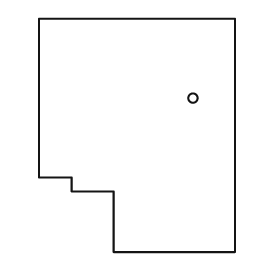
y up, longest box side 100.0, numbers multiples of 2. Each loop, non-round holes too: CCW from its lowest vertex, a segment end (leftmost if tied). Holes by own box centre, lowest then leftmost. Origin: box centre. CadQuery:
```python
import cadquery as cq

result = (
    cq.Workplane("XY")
    .moveTo(-10.0, -50.0)
    .lineTo(42.0, -50.0)
    .lineTo(42.0, 50.0)
    .lineTo(-42.0, 50.0)
    .lineTo(-42.0, -18.0)
    .lineTo(-28.0, -18.0)
    .lineTo(-28.0, -24.0)
    .lineTo(-10.0, -24.0)
    .close()
    .moveTo(24.0, 16.0)
    .circle(2.0)
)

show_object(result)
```